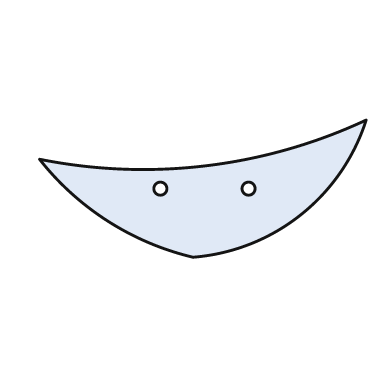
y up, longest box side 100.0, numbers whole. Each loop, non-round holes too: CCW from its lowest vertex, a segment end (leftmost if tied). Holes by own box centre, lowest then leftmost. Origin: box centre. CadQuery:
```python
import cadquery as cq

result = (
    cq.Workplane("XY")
    .moveTo(-3.0, -21.0)
    .threePointArc((30.0, -8.0), (50.0, 21.0))
    .threePointArc((1.0, 7.0), (-50.0, 9.0))
    .threePointArc((-29.0, -10.0), (-3.0, -21.0))
    .close()
    .moveTo(-13.0, 0.0)
    .circle(2.0)
    .moveTo(14.0, 0.0)
    .circle(2.0)
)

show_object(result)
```